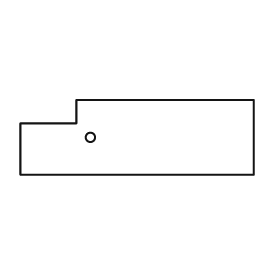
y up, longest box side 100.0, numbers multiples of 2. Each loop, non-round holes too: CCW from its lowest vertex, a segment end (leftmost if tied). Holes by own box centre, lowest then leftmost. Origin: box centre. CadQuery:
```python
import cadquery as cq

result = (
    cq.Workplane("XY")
    .moveTo(-50.0, -16.0)
    .lineTo(50.0, -16.0)
    .lineTo(50.0, 16.0)
    .lineTo(-26.0, 16.0)
    .lineTo(-26.0, 6.0)
    .lineTo(-50.0, 6.0)
    .close()
    .moveTo(-20.0, 0.0)
    .circle(2.0)
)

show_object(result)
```